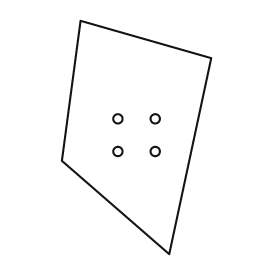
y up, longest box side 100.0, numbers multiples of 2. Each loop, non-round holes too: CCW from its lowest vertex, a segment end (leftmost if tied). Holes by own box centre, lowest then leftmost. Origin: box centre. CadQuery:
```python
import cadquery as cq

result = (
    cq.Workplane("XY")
    .moveTo(14.0, -50.0)
    .lineTo(32.0, 34.0)
    .lineTo(-24.0, 50.0)
    .lineTo(-32.0, -10.0)
    .close()
    .moveTo(-8.0, -6.0)
    .circle(2.0)
    .moveTo(8.0, -6.0)
    .circle(2.0)
    .moveTo(-8.0, 8.0)
    .circle(2.0)
    .moveTo(8.0, 8.0)
    .circle(2.0)
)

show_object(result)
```